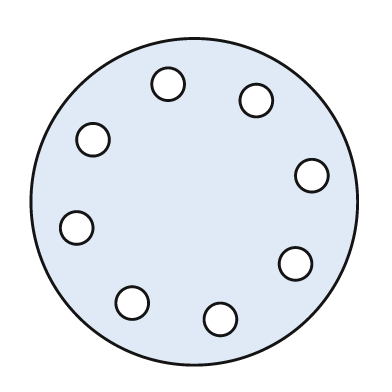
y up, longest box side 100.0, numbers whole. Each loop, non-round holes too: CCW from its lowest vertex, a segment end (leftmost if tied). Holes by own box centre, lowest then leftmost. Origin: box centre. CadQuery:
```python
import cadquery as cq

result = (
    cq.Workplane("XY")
    .moveTo(0.0, 0.0)
    .circle(50.0)
    .moveTo(8.0, -36.0)
    .circle(5.0)
    .moveTo(-19.0, -31.0)
    .circle(5.0)
    .moveTo(31.0, -19.0)
    .circle(5.0)
    .moveTo(-36.0, -8.0)
    .circle(5.0)
    .moveTo(36.0, 8.0)
    .circle(5.0)
    .moveTo(-31.0, 19.0)
    .circle(5.0)
    .moveTo(19.0, 31.0)
    .circle(5.0)
    .moveTo(-8.0, 36.0)
    .circle(5.0)
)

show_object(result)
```